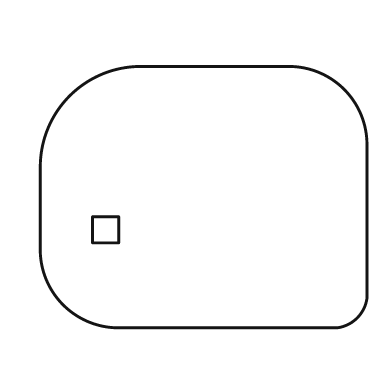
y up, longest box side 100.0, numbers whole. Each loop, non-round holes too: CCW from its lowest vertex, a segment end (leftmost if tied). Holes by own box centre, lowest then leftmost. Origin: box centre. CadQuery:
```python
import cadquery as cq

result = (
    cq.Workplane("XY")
    .moveTo(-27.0, -40.0)
    .lineTo(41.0, -40.0)
    .threePointArc((47.0, -37.0), (50.0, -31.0))
    .lineTo(50.0, 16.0)
    .threePointArc((43.0, 33.0), (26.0, 40.0))
    .lineTo(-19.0, 40.0)
    .threePointArc((-41.0, 31.0), (-50.0, 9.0))
    .lineTo(-50.0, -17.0)
    .threePointArc((-43.0, -33.0), (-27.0, -40.0))
    .close()
    .moveTo(-34.0, -14.0)
    .lineTo(-26.0, -14.0)
    .lineTo(-26.0, -6.0)
    .lineTo(-34.0, -6.0)
    .close()
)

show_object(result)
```